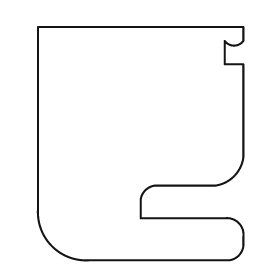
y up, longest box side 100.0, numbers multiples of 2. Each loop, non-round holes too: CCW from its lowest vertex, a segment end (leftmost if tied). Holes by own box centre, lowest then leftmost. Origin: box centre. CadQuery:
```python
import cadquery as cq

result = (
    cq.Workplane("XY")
    .moveTo(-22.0, -50.0)
    .lineTo(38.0, -50.0)
    .threePointArc((42.0, -48.0), (44.0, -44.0))
    .lineTo(44.0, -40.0)
    .threePointArc((42.0, -34.0), (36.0, -32.0))
    .lineTo(0.0, -32.0)
    .lineTo(0.0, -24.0)
    .threePointArc((2.0, -20.0), (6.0, -18.0))
    .lineTo(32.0, -18.0)
    .threePointArc((40.0, -14.0), (44.0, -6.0))
    .lineTo(44.0, 34.0)
    .lineTo(36.0, 34.0)
    .lineTo(36.0, 44.0)
    .threePointArc((40.0, 42.0), (44.0, 44.0))
    .lineTo(44.0, 50.0)
    .lineTo(-44.0, 50.0)
    .lineTo(-44.0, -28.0)
    .threePointArc((-38.0, -44.0), (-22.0, -50.0))
    .close()
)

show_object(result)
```